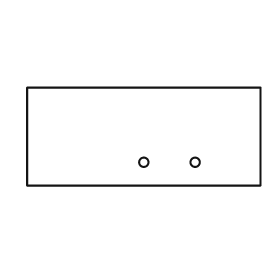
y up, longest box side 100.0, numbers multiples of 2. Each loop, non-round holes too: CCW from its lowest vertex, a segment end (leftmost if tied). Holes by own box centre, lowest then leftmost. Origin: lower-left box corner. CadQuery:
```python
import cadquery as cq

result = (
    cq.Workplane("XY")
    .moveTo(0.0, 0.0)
    .lineTo(100.0, 0.0)
    .lineTo(100.0, 42.0)
    .lineTo(0.0, 42.0)
    .close()
    .moveTo(50.0, 10.0)
    .circle(2.0)
    .moveTo(72.0, 10.0)
    .circle(2.0)
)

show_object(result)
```